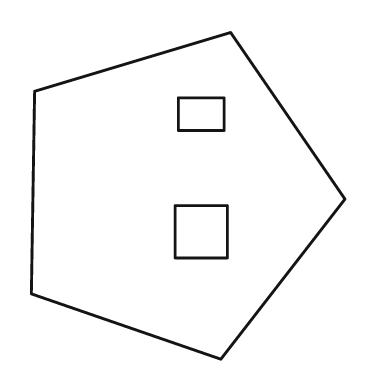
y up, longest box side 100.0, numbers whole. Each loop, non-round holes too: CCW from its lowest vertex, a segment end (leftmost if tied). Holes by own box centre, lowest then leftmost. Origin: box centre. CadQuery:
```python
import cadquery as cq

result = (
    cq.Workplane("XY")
    .moveTo(10.0, -50.0)
    .lineTo(48.0, -1.0)
    .lineTo(13.0, 50.0)
    .lineTo(-47.0, 32.0)
    .lineTo(-48.0, -30.0)
    .close()
    .moveTo(-4.0, -19.0)
    .lineTo(12.0, -19.0)
    .lineTo(12.0, -3.0)
    .lineTo(-4.0, -3.0)
    .close()
    .moveTo(-3.0, 20.0)
    .lineTo(11.0, 20.0)
    .lineTo(11.0, 30.0)
    .lineTo(-3.0, 30.0)
    .close()
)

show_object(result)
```